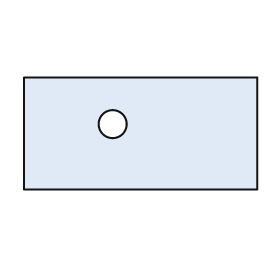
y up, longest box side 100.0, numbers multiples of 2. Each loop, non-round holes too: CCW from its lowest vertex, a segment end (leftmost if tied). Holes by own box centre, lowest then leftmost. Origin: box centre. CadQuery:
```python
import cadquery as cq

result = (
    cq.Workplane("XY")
    .moveTo(-50.0, -24.0)
    .lineTo(50.0, -24.0)
    .lineTo(50.0, 24.0)
    .lineTo(-50.0, 24.0)
    .close()
    .moveTo(-12.0, 4.0)
    .circle(6.0)
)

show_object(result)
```